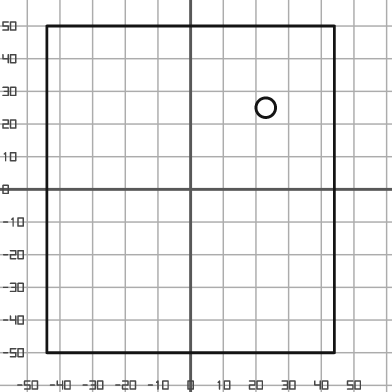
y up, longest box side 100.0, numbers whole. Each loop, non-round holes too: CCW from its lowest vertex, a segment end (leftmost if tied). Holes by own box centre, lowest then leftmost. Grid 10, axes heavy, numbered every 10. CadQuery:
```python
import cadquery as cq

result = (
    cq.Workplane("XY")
    .moveTo(-44.0, -50.0)
    .lineTo(44.0, -50.0)
    .lineTo(44.0, 50.0)
    .lineTo(-44.0, 50.0)
    .close()
    .moveTo(23.0, 25.0)
    .circle(3.0)
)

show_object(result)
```